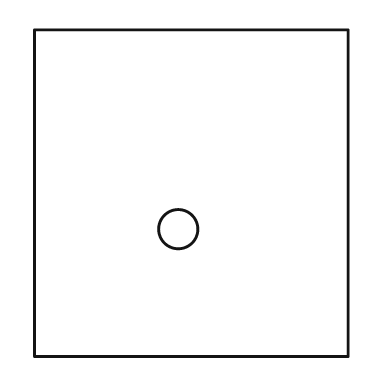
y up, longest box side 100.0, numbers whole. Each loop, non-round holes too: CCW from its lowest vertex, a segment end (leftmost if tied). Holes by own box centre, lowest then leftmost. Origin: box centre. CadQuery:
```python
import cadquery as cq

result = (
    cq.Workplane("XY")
    .moveTo(-48.0, -50.0)
    .lineTo(48.0, -50.0)
    .lineTo(48.0, 50.0)
    .lineTo(-48.0, 50.0)
    .close()
    .moveTo(-4.0, -11.0)
    .circle(6.0)
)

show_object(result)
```